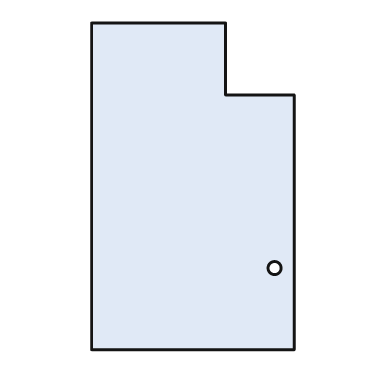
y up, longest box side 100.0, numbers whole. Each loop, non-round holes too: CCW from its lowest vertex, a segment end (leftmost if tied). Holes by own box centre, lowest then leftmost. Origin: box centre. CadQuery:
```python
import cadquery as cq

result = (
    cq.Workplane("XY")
    .moveTo(-31.0, -50.0)
    .lineTo(31.0, -50.0)
    .lineTo(31.0, 28.0)
    .lineTo(10.0, 28.0)
    .lineTo(10.0, 50.0)
    .lineTo(-31.0, 50.0)
    .close()
    .moveTo(25.0, -25.0)
    .circle(2.0)
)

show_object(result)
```